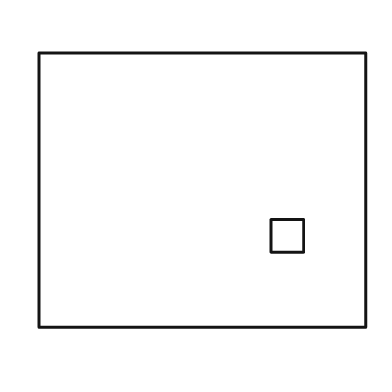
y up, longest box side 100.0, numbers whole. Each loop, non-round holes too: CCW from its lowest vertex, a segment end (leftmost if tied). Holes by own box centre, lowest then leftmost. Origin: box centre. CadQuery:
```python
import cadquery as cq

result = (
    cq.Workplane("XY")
    .moveTo(-50.0, -42.0)
    .lineTo(50.0, -42.0)
    .lineTo(50.0, 42.0)
    .lineTo(-50.0, 42.0)
    .close()
    .moveTo(21.0, -19.0)
    .lineTo(31.0, -19.0)
    .lineTo(31.0, -9.0)
    .lineTo(21.0, -9.0)
    .close()
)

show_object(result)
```